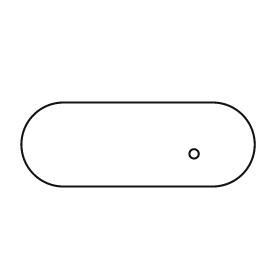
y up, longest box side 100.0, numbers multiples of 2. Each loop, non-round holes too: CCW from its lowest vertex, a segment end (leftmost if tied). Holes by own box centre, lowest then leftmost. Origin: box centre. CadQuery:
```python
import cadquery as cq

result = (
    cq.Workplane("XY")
    .moveTo(-32.0, -18.0)
    .lineTo(32.0, -18.0)
    .threePointArc((50.0, 0.0), (32.0, 18.0))
    .lineTo(-32.0, 18.0)
    .threePointArc((-50.0, 0.0), (-32.0, -18.0))
    .close()
    .moveTo(24.0, -4.0)
    .circle(2.0)
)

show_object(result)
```